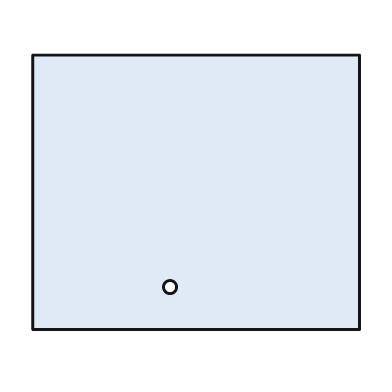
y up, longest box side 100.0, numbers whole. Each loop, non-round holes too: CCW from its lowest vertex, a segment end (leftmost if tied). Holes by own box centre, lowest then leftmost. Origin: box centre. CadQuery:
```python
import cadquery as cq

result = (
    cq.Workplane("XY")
    .moveTo(-50.0, -42.0)
    .lineTo(50.0, -42.0)
    .lineTo(50.0, 42.0)
    .lineTo(-50.0, 42.0)
    .close()
    .moveTo(-8.0, -29.0)
    .circle(2.0)
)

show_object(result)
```